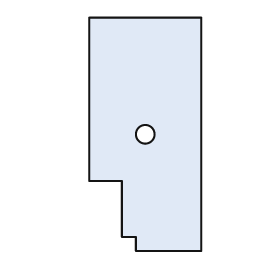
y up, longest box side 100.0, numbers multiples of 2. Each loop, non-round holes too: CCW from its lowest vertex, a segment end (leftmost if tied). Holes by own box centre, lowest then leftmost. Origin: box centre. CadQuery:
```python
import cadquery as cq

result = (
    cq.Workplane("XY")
    .moveTo(-4.0, -50.0)
    .lineTo(24.0, -50.0)
    .lineTo(24.0, 50.0)
    .lineTo(-24.0, 50.0)
    .lineTo(-24.0, -20.0)
    .lineTo(-10.0, -20.0)
    .lineTo(-10.0, -44.0)
    .lineTo(-4.0, -44.0)
    .close()
    .moveTo(0.0, 0.0)
    .circle(4.0)
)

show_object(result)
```